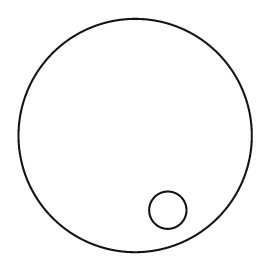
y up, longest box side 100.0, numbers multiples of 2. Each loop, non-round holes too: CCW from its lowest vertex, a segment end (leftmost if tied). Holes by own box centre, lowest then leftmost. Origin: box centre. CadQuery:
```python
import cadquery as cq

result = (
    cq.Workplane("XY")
    .moveTo(0.0, 0.0)
    .circle(50.0)
    .moveTo(14.0, -32.0)
    .circle(8.0)
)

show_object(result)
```